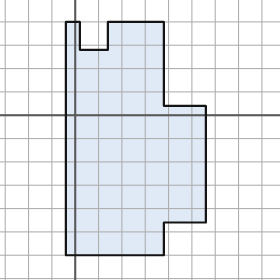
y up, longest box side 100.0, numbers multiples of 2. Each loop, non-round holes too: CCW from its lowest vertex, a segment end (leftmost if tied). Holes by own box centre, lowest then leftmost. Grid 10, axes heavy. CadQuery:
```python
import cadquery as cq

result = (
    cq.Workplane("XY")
    .moveTo(-4.0, -60.0)
    .lineTo(38.0, -60.0)
    .lineTo(38.0, -46.0)
    .lineTo(56.0, -46.0)
    .lineTo(56.0, 4.0)
    .lineTo(38.0, 4.0)
    .lineTo(38.0, 40.0)
    .lineTo(14.0, 40.0)
    .lineTo(14.0, 28.0)
    .lineTo(2.0, 28.0)
    .lineTo(2.0, 40.0)
    .lineTo(-4.0, 40.0)
    .close()
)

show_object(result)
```